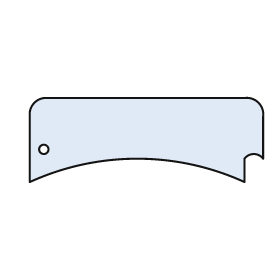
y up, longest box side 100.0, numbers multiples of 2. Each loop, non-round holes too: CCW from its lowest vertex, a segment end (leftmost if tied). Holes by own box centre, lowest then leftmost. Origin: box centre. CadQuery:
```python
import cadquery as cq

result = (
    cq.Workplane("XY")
    .moveTo(-50.0, -18.0)
    .threePointArc((-4.0, -8.0), (42.0, -18.0))
    .lineTo(42.0, -8.0)
    .threePointArc((46.0, -6.0), (50.0, -8.0))
    .lineTo(50.0, 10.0)
    .threePointArc((48.0, 16.0), (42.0, 18.0))
    .lineTo(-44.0, 18.0)
    .threePointArc((-48.0, 16.0), (-50.0, 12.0))
    .close()
    .moveTo(-44.0, -4.0)
    .circle(2.0)
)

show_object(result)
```